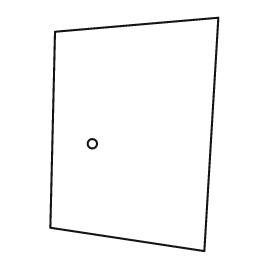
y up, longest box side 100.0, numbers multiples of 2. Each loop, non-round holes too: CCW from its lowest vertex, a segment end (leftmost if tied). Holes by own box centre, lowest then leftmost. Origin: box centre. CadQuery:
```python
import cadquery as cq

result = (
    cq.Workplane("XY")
    .moveTo(30.0, -50.0)
    .lineTo(36.0, 50.0)
    .lineTo(-34.0, 44.0)
    .lineTo(-36.0, -40.0)
    .close()
    .moveTo(-18.0, -4.0)
    .circle(2.0)
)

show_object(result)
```